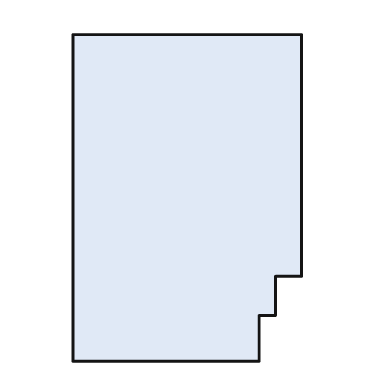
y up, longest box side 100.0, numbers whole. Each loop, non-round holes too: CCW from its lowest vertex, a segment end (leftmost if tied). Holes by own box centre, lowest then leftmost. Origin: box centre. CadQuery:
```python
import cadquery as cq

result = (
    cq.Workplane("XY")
    .moveTo(-35.0, -50.0)
    .lineTo(22.0, -50.0)
    .lineTo(22.0, -36.0)
    .lineTo(27.0, -36.0)
    .lineTo(27.0, -24.0)
    .lineTo(35.0, -24.0)
    .lineTo(35.0, 50.0)
    .lineTo(-35.0, 50.0)
    .close()
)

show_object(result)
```